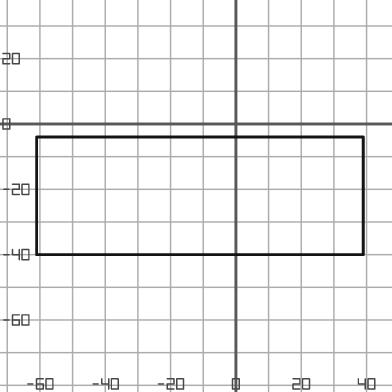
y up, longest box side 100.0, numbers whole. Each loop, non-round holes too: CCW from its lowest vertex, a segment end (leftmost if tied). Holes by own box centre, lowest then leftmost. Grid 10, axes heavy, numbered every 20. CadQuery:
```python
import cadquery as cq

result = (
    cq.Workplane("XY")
    .moveTo(-61.0, -40.0)
    .lineTo(39.0, -40.0)
    .lineTo(39.0, -4.0)
    .lineTo(-61.0, -4.0)
    .close()
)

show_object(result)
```